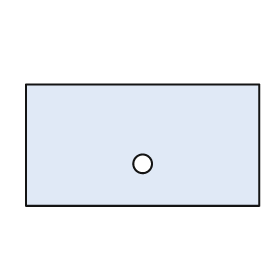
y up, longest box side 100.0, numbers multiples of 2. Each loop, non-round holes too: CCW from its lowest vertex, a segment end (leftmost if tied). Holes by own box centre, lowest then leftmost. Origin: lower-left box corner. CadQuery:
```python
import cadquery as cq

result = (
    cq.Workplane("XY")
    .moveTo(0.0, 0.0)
    .lineTo(100.0, 0.0)
    .lineTo(100.0, 52.0)
    .lineTo(0.0, 52.0)
    .close()
    .moveTo(50.0, 18.0)
    .circle(4.0)
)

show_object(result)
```